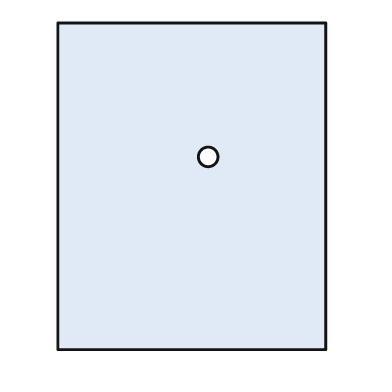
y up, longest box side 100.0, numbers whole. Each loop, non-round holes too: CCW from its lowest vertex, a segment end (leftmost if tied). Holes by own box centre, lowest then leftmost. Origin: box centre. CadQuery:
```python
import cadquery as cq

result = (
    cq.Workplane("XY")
    .moveTo(-41.0, -50.0)
    .lineTo(41.0, -50.0)
    .lineTo(41.0, 50.0)
    .lineTo(-41.0, 50.0)
    .close()
    .moveTo(5.0, 9.0)
    .circle(3.0)
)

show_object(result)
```